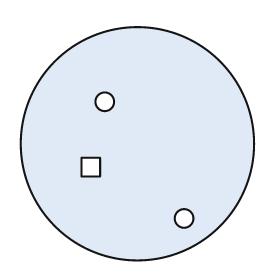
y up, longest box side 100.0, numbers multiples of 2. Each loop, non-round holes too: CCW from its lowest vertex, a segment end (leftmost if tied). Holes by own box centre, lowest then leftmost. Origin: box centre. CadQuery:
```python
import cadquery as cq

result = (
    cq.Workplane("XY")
    .moveTo(0.0, 0.0)
    .circle(50.0)
    .moveTo(20.0, -32.0)
    .circle(4.0)
    .moveTo(-24.0, -14.0)
    .lineTo(-16.0, -14.0)
    .lineTo(-16.0, -6.0)
    .lineTo(-24.0, -6.0)
    .close()
    .moveTo(-14.0, 18.0)
    .circle(4.0)
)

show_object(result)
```